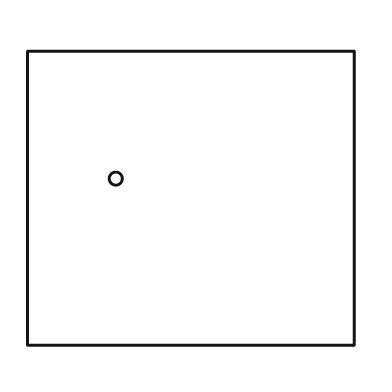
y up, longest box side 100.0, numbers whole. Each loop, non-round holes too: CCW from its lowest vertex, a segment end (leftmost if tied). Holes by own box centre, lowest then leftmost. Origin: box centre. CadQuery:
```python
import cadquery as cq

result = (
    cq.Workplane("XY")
    .moveTo(-50.0, -45.0)
    .lineTo(50.0, -45.0)
    .lineTo(50.0, 45.0)
    .lineTo(-50.0, 45.0)
    .close()
    .moveTo(-23.0, 6.0)
    .circle(2.0)
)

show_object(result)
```